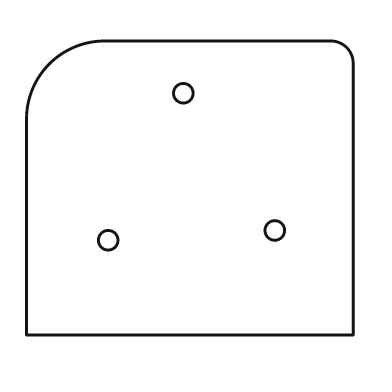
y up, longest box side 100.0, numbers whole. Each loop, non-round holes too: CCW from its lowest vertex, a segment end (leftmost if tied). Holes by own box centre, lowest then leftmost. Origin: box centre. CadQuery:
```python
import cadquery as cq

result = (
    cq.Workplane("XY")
    .moveTo(-50.0, -45.0)
    .lineTo(50.0, -45.0)
    .lineTo(50.0, 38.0)
    .threePointArc((48.0, 43.0), (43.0, 45.0))
    .lineTo(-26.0, 45.0)
    .threePointArc((-43.0, 38.0), (-50.0, 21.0))
    .close()
    .moveTo(-25.0, -16.0)
    .circle(3.0)
    .moveTo(26.0, -13.0)
    .circle(3.0)
    .moveTo(-2.0, 29.0)
    .circle(3.0)
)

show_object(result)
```